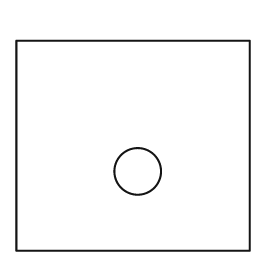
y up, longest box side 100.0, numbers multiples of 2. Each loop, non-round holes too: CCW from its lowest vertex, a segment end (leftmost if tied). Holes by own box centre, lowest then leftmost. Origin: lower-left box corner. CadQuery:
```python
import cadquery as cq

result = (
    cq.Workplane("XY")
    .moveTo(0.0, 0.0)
    .lineTo(100.0, 0.0)
    .lineTo(100.0, 90.0)
    .lineTo(0.0, 90.0)
    .close()
    .moveTo(52.0, 34.0)
    .circle(10.0)
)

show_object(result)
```